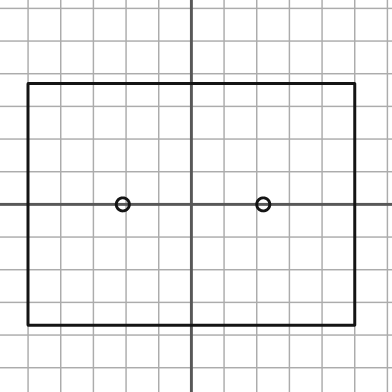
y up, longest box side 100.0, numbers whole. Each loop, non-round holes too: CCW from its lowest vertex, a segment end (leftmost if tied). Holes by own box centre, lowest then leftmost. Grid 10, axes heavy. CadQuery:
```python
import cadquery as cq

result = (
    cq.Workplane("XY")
    .moveTo(-50.0, -37.0)
    .lineTo(50.0, -37.0)
    .lineTo(50.0, 37.0)
    .lineTo(-50.0, 37.0)
    .close()
    .moveTo(-21.0, 0.0)
    .circle(2.0)
    .moveTo(22.0, 0.0)
    .circle(2.0)
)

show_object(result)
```